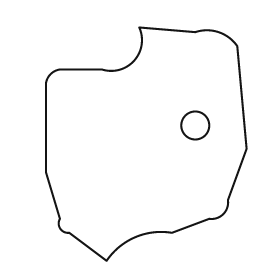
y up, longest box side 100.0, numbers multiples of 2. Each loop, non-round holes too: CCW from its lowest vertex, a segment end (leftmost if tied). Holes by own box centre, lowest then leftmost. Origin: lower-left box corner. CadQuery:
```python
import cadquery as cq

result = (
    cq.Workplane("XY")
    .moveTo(26.0, 0.0)
    .threePointArc((38.0, 10.0), (54.0, 12.0))
    .lineTo(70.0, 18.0)
    .threePointArc((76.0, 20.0), (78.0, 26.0))
    .lineTo(86.0, 48.0)
    .lineTo(82.0, 92.0)
    .threePointArc((74.0, 98.0), (64.0, 98.0))
    .lineTo(40.0, 100.0)
    .threePointArc((38.0, 86.0), (24.0, 82.0))
    .lineTo(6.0, 82.0)
    .threePointArc((2.0, 80.0), (0.0, 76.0))
    .lineTo(0.0, 38.0)
    .lineTo(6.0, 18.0)
    .threePointArc((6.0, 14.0), (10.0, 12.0))
    .close()
    .moveTo(64.0, 58.0)
    .circle(6.0)
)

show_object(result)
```